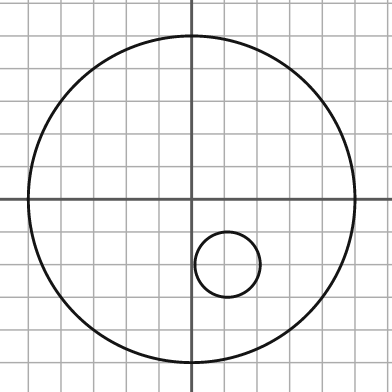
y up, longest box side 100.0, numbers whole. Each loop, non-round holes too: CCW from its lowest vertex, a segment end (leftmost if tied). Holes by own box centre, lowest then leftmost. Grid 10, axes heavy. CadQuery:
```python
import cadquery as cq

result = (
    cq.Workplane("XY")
    .moveTo(0.0, 0.0)
    .circle(50.0)
    .moveTo(11.0, -20.0)
    .circle(10.0)
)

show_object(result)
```